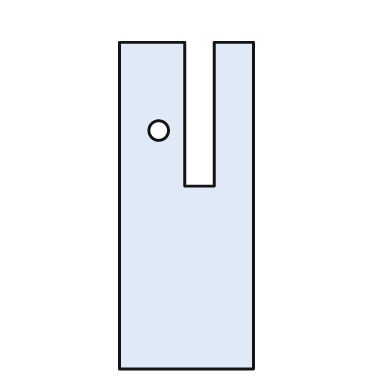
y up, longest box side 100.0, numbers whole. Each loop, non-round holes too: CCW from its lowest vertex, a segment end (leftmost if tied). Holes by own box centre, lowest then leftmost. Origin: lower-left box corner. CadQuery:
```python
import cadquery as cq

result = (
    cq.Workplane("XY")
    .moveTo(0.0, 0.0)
    .lineTo(41.0, 0.0)
    .lineTo(41.0, 100.0)
    .lineTo(29.0, 100.0)
    .lineTo(29.0, 56.0)
    .lineTo(20.0, 56.0)
    .lineTo(20.0, 100.0)
    .lineTo(0.0, 100.0)
    .close()
    .moveTo(12.0, 73.0)
    .circle(3.0)
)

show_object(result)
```